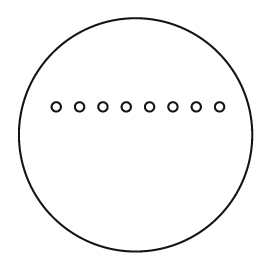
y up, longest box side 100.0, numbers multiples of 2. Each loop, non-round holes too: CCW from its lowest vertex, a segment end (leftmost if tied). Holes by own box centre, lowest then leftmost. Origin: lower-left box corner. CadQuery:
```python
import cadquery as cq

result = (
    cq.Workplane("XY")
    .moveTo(50.0, 50.0)
    .circle(50.0)
    .moveTo(16.0, 62.0)
    .circle(2.0)
    .moveTo(26.0, 62.0)
    .circle(2.0)
    .moveTo(36.0, 62.0)
    .circle(2.0)
    .moveTo(46.0, 62.0)
    .circle(2.0)
    .moveTo(56.0, 62.0)
    .circle(2.0)
    .moveTo(66.0, 62.0)
    .circle(2.0)
    .moveTo(76.0, 62.0)
    .circle(2.0)
    .moveTo(86.0, 62.0)
    .circle(2.0)
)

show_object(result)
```